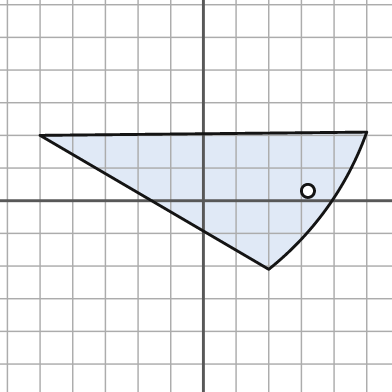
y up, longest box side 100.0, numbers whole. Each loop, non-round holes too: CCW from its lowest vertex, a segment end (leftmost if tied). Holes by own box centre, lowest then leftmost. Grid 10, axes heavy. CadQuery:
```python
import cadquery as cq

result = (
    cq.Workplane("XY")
    .moveTo(20.0, -21.0)
    .threePointArc((38.0, -2.0), (50.0, 21.0))
    .lineTo(-50.0, 20.0)
    .close()
    .moveTo(32.0, 3.0)
    .circle(2.0)
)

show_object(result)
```